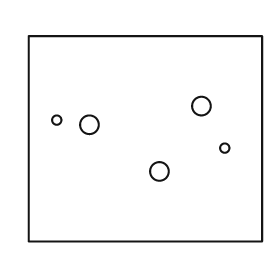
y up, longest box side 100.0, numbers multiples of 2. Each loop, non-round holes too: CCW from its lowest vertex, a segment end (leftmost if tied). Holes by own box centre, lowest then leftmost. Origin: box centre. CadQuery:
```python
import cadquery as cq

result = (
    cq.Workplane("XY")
    .moveTo(-50.0, -44.0)
    .lineTo(50.0, -44.0)
    .lineTo(50.0, 44.0)
    .lineTo(-50.0, 44.0)
    .close()
    .moveTo(6.0, -14.0)
    .circle(4.0)
    .moveTo(34.0, -4.0)
    .circle(2.0)
    .moveTo(-24.0, 6.0)
    .circle(4.0)
    .moveTo(-38.0, 8.0)
    .circle(2.0)
    .moveTo(24.0, 14.0)
    .circle(4.0)
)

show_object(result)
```